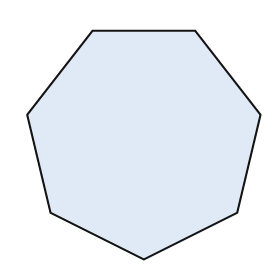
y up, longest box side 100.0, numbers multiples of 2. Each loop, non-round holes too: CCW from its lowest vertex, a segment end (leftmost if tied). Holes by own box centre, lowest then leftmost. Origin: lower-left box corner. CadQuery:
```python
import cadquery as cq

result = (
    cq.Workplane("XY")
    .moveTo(50.0, 0.0)
    .lineTo(90.0, 20.0)
    .lineTo(100.0, 62.0)
    .lineTo(72.0, 98.0)
    .lineTo(28.0, 98.0)
    .lineTo(0.0, 62.0)
    .lineTo(10.0, 20.0)
    .close()
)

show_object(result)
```